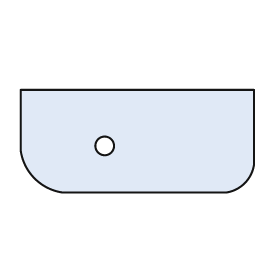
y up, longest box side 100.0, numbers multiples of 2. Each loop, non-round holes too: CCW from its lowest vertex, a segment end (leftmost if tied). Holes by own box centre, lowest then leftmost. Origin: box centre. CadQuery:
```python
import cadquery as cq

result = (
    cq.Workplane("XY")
    .moveTo(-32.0, -22.0)
    .lineTo(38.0, -22.0)
    .threePointArc((46.0, -18.0), (50.0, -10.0))
    .lineTo(50.0, 22.0)
    .lineTo(-50.0, 22.0)
    .lineTo(-50.0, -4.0)
    .threePointArc((-44.0, -16.0), (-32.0, -22.0))
    .close()
    .moveTo(-14.0, -2.0)
    .circle(4.0)
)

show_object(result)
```